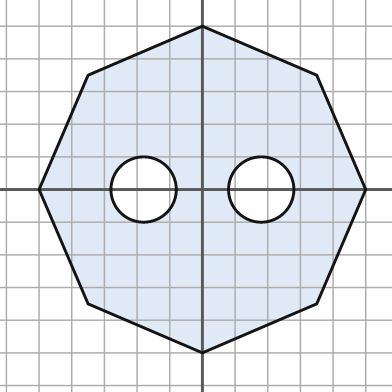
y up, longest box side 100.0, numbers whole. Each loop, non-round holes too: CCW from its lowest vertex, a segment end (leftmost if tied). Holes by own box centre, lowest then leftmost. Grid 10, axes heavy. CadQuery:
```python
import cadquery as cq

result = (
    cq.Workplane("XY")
    .moveTo(0.0, -50.0)
    .lineTo(35.0, -35.0)
    .lineTo(50.0, 0.0)
    .lineTo(35.0, 35.0)
    .lineTo(0.0, 50.0)
    .lineTo(-35.0, 35.0)
    .lineTo(-50.0, 0.0)
    .lineTo(-35.0, -35.0)
    .close()
    .moveTo(-18.0, 0.0)
    .circle(10.0)
    .moveTo(18.0, 0.0)
    .circle(10.0)
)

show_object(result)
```